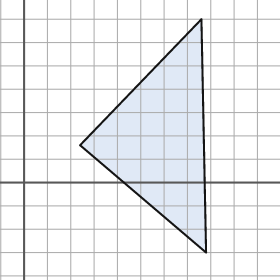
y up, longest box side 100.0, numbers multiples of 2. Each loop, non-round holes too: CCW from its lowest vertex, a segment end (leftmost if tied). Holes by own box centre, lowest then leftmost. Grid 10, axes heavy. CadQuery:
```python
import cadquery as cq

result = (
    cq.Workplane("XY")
    .moveTo(78.0, -30.0)
    .lineTo(76.0, 70.0)
    .lineTo(24.0, 16.0)
    .close()
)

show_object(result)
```